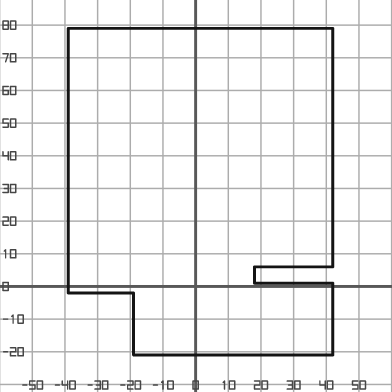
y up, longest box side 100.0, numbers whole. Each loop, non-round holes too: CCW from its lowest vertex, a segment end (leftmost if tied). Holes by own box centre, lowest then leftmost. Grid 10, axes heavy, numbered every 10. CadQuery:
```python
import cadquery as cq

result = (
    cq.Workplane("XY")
    .moveTo(-19.0, -21.0)
    .lineTo(42.0, -21.0)
    .lineTo(42.0, 1.0)
    .lineTo(18.0, 1.0)
    .lineTo(18.0, 6.0)
    .lineTo(42.0, 6.0)
    .lineTo(42.0, 79.0)
    .lineTo(-39.0, 79.0)
    .lineTo(-39.0, -2.0)
    .lineTo(-19.0, -2.0)
    .close()
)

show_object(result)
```